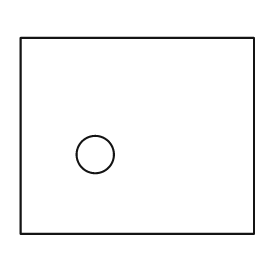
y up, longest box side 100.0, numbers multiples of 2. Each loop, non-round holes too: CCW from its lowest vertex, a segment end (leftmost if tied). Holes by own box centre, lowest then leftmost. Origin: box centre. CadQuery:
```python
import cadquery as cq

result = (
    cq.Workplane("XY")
    .moveTo(-50.0, -42.0)
    .lineTo(50.0, -42.0)
    .lineTo(50.0, 42.0)
    .lineTo(-50.0, 42.0)
    .close()
    .moveTo(-18.0, -8.0)
    .circle(8.0)
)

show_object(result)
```